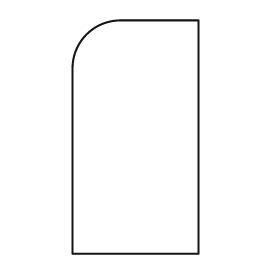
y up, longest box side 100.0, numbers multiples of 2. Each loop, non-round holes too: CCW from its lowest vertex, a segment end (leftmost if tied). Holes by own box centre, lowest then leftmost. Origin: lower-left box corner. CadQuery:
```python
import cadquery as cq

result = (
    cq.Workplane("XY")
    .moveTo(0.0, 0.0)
    .lineTo(54.0, 0.0)
    .lineTo(54.0, 100.0)
    .lineTo(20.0, 100.0)
    .threePointArc((6.0, 94.0), (0.0, 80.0))
    .close()
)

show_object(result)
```